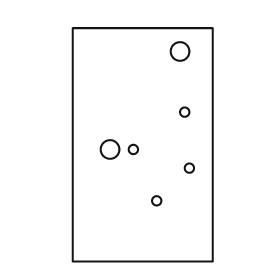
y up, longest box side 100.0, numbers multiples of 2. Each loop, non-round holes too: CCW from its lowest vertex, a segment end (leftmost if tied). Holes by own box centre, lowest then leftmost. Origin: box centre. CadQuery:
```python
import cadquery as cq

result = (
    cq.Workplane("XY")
    .moveTo(-30.0, -50.0)
    .lineTo(30.0, -50.0)
    .lineTo(30.0, 50.0)
    .lineTo(-30.0, 50.0)
    .close()
    .moveTo(6.0, -24.0)
    .circle(2.0)
    .moveTo(20.0, -10.0)
    .circle(2.0)
    .moveTo(-14.0, -2.0)
    .circle(4.0)
    .moveTo(-4.0, -2.0)
    .circle(2.0)
    .moveTo(18.0, 14.0)
    .circle(2.0)
    .moveTo(16.0, 40.0)
    .circle(4.0)
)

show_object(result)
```